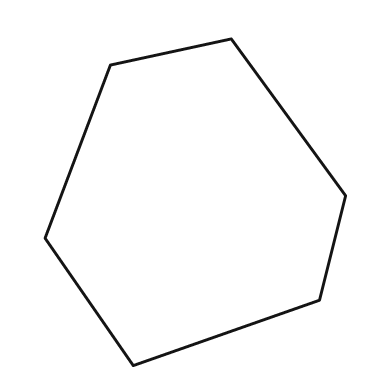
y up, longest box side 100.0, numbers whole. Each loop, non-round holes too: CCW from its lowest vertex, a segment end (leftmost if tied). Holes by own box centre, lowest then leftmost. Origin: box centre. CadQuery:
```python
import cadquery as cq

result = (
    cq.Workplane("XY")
    .moveTo(-19.0, -50.0)
    .lineTo(38.0, -30.0)
    .lineTo(46.0, 2.0)
    .lineTo(11.0, 50.0)
    .lineTo(-26.0, 42.0)
    .lineTo(-46.0, -11.0)
    .close()
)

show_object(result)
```